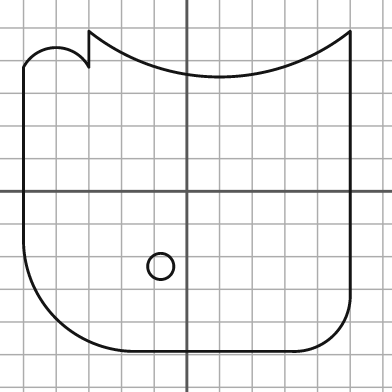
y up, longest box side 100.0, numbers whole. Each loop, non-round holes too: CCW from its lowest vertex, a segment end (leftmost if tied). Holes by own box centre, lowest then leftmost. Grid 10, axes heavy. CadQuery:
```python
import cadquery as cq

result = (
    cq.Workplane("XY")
    .moveTo(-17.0, -49.0)
    .lineTo(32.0, -49.0)
    .threePointArc((45.0, -44.0), (50.0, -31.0))
    .lineTo(50.0, 49.0)
    .threePointArc((10.0, 35.0), (-30.0, 49.0))
    .lineTo(-30.0, 38.0)
    .threePointArc((-40.0, 44.0), (-50.0, 38.0))
    .lineTo(-50.0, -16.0)
    .threePointArc((-40.0, -39.0), (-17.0, -49.0))
    .close()
    .moveTo(-8.0, -23.0)
    .circle(4.0)
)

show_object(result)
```